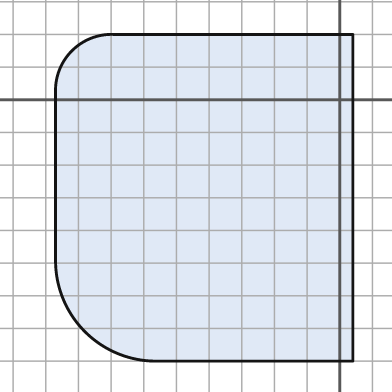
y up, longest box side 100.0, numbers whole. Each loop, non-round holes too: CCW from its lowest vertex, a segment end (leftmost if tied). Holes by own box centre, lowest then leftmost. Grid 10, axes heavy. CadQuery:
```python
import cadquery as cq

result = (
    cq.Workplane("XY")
    .moveTo(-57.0, -80.0)
    .lineTo(4.0, -80.0)
    .lineTo(4.0, 20.0)
    .lineTo(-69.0, 20.0)
    .threePointArc((-82.0, 15.0), (-87.0, 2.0))
    .lineTo(-87.0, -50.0)
    .threePointArc((-78.0, -71.0), (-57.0, -80.0))
    .close()
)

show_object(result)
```